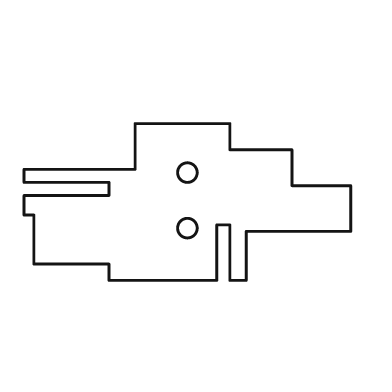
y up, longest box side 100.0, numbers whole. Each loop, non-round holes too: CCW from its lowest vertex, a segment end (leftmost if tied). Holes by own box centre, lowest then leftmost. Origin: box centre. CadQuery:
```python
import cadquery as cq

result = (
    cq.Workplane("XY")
    .moveTo(-24.0, -24.0)
    .lineTo(9.0, -24.0)
    .lineTo(9.0, -7.0)
    .lineTo(13.0, -7.0)
    .lineTo(13.0, -24.0)
    .lineTo(18.0, -24.0)
    .lineTo(18.0, -9.0)
    .lineTo(50.0, -9.0)
    .lineTo(50.0, 5.0)
    .lineTo(32.0, 5.0)
    .lineTo(32.0, 16.0)
    .lineTo(13.0, 16.0)
    .lineTo(13.0, 24.0)
    .lineTo(-16.0, 24.0)
    .lineTo(-16.0, 10.0)
    .lineTo(-50.0, 10.0)
    .lineTo(-50.0, 6.0)
    .lineTo(-24.0, 6.0)
    .lineTo(-24.0, 2.0)
    .lineTo(-50.0, 2.0)
    .lineTo(-50.0, -4.0)
    .lineTo(-47.0, -4.0)
    .lineTo(-47.0, -19.0)
    .lineTo(-24.0, -19.0)
    .close()
    .moveTo(0.0, -8.0)
    .circle(3.0)
    .moveTo(0.0, 9.0)
    .circle(3.0)
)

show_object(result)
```